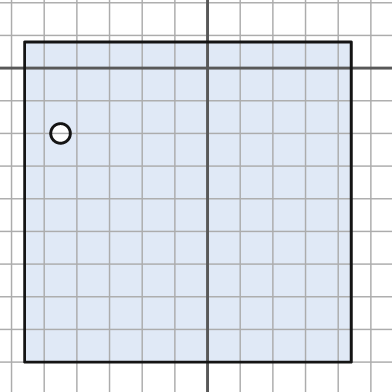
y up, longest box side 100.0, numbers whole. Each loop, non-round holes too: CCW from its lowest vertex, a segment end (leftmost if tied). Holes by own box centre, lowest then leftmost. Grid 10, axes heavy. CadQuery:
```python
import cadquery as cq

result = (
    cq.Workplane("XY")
    .moveTo(-56.0, -90.0)
    .lineTo(44.0, -90.0)
    .lineTo(44.0, 8.0)
    .lineTo(-56.0, 8.0)
    .close()
    .moveTo(-45.0, -20.0)
    .circle(3.0)
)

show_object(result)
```